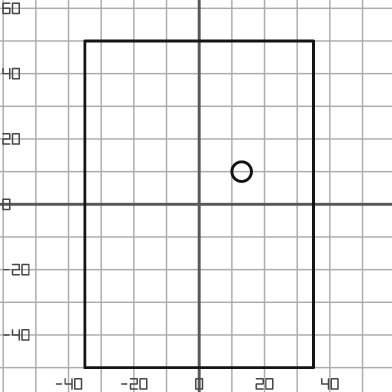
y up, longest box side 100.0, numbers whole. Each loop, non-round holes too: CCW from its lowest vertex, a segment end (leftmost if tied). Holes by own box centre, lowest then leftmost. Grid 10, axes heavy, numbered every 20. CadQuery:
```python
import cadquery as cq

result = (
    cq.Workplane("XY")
    .moveTo(-35.0, -50.0)
    .lineTo(35.0, -50.0)
    .lineTo(35.0, 50.0)
    .lineTo(-35.0, 50.0)
    .close()
    .moveTo(13.0, 10.0)
    .circle(3.0)
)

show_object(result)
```